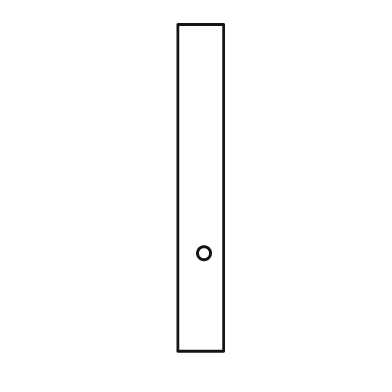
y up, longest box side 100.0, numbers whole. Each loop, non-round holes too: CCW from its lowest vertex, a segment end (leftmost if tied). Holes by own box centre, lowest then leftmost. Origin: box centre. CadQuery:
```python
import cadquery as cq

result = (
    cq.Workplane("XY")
    .moveTo(-7.0, -50.0)
    .lineTo(7.0, -50.0)
    .lineTo(7.0, 50.0)
    .lineTo(-7.0, 50.0)
    .close()
    .moveTo(1.0, -20.0)
    .circle(2.0)
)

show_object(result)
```